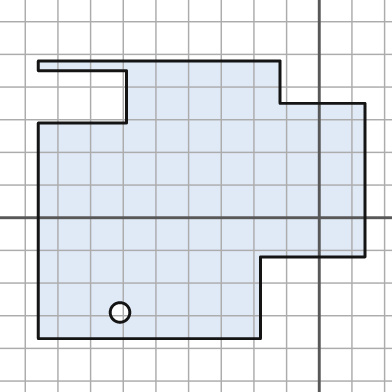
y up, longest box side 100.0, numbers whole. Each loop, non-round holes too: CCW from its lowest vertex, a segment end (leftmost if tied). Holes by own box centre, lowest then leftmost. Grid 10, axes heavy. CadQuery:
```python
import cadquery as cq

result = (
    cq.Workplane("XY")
    .moveTo(-86.0, -37.0)
    .lineTo(-18.0, -37.0)
    .lineTo(-18.0, -12.0)
    .lineTo(14.0, -12.0)
    .lineTo(14.0, 35.0)
    .lineTo(-12.0, 35.0)
    .lineTo(-12.0, 48.0)
    .lineTo(-86.0, 48.0)
    .lineTo(-86.0, 45.0)
    .lineTo(-59.0, 45.0)
    .lineTo(-59.0, 29.0)
    .lineTo(-86.0, 29.0)
    .close()
    .moveTo(-61.0, -29.0)
    .circle(3.0)
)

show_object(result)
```